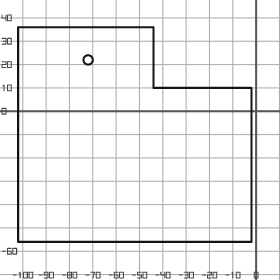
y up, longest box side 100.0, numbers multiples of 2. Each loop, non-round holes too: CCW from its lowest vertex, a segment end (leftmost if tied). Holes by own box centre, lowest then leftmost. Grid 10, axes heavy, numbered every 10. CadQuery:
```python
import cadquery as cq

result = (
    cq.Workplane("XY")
    .moveTo(-102.0, -56.0)
    .lineTo(-2.0, -56.0)
    .lineTo(-2.0, 10.0)
    .lineTo(-44.0, 10.0)
    .lineTo(-44.0, 36.0)
    .lineTo(-102.0, 36.0)
    .close()
    .moveTo(-72.0, 22.0)
    .circle(2.0)
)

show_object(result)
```